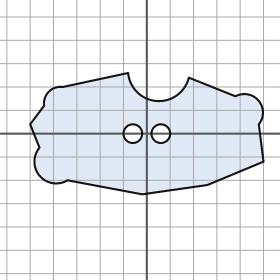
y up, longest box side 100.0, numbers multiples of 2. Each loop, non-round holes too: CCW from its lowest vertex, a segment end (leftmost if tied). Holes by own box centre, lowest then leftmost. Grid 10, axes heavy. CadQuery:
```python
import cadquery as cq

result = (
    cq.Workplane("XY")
    .moveTo(-2.0, -26.0)
    .lineTo(26.0, -22.0)
    .lineTo(50.0, -12.0)
    .lineTo(48.0, 4.0)
    .threePointArc((48.0, 14.0), (38.0, 16.0))
    .lineTo(18.0, 24.0)
    .threePointArc((4.0, 14.0), (-8.0, 26.0))
    .lineTo(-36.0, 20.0)
    .threePointArc((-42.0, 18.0), (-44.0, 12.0))
    .lineTo(-50.0, 4.0)
    .lineTo(-46.0, -6.0)
    .threePointArc((-46.0, -18.0), (-34.0, -20.0))
    .close()
    .moveTo(-6.0, 0.0)
    .circle(4.0)
    .moveTo(6.0, 0.0)
    .circle(4.0)
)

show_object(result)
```